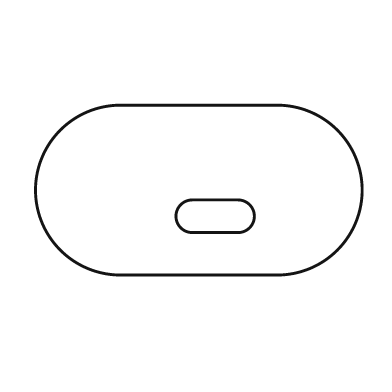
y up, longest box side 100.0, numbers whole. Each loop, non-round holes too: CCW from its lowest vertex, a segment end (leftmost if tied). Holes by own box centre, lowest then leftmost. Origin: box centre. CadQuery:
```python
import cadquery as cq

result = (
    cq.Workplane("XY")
    .moveTo(-24.0, -26.0)
    .lineTo(24.0, -26.0)
    .threePointArc((50.0, 0.0), (24.0, 26.0))
    .lineTo(-24.0, 26.0)
    .threePointArc((-50.0, 0.0), (-24.0, -26.0))
    .close()
    .moveTo(-2.0, -13.0)
    .lineTo(12.0, -13.0)
    .threePointArc((17.0, -8.0), (12.0, -3.0))
    .lineTo(-2.0, -3.0)
    .threePointArc((-7.0, -8.0), (-2.0, -13.0))
    .close()
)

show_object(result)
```